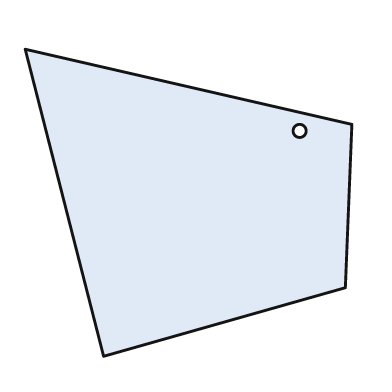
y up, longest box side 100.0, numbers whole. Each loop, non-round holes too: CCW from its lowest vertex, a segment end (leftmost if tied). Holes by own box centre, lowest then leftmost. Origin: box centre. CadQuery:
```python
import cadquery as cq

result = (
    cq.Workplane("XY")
    .moveTo(-26.0, -47.0)
    .lineTo(48.0, -26.0)
    .lineTo(50.0, 24.0)
    .lineTo(-50.0, 47.0)
    .close()
    .moveTo(34.0, 22.0)
    .circle(2.0)
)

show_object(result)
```